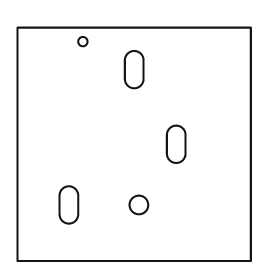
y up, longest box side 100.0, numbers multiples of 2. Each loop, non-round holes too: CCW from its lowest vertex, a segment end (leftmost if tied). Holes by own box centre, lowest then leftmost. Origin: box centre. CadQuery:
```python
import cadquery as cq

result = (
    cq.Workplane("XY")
    .moveTo(-50.0, -50.0)
    .lineTo(50.0, -50.0)
    .lineTo(50.0, 50.0)
    .lineTo(-50.0, 50.0)
    .close()
    .moveTo(-32.0, -30.0)
    .threePointArc((-28.0, -34.0), (-24.0, -30.0))
    .lineTo(-24.0, -22.0)
    .threePointArc((-28.0, -18.0), (-32.0, -22.0))
    .close()
    .moveTo(2.0, -26.0)
    .circle(4.0)
    .moveTo(14.0, -4.0)
    .threePointArc((18.0, -8.0), (22.0, -4.0))
    .lineTo(22.0, 4.0)
    .threePointArc((18.0, 8.0), (14.0, 4.0))
    .close()
    .moveTo(-4.0, 28.0)
    .threePointArc((0.0, 24.0), (4.0, 28.0))
    .lineTo(4.0, 36.0)
    .threePointArc((0.0, 40.0), (-4.0, 36.0))
    .close()
    .moveTo(-22.0, 44.0)
    .circle(2.0)
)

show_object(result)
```